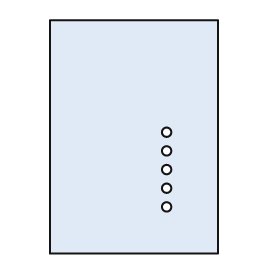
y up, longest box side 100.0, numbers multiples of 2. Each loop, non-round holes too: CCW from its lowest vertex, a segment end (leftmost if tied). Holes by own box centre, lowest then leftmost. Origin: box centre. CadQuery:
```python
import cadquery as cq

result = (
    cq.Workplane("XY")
    .moveTo(-36.0, -50.0)
    .lineTo(36.0, -50.0)
    .lineTo(36.0, 50.0)
    .lineTo(-36.0, 50.0)
    .close()
    .moveTo(14.0, -30.0)
    .circle(2.0)
    .moveTo(14.0, -22.0)
    .circle(2.0)
    .moveTo(14.0, -14.0)
    .circle(2.0)
    .moveTo(14.0, -6.0)
    .circle(2.0)
    .moveTo(14.0, 2.0)
    .circle(2.0)
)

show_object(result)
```